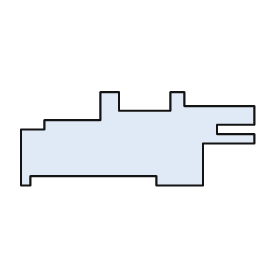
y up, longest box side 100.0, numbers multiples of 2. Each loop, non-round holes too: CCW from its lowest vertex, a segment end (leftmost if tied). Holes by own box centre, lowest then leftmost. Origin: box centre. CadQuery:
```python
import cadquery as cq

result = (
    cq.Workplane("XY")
    .moveTo(-50.0, -20.0)
    .lineTo(-46.0, -20.0)
    .lineTo(-46.0, -16.0)
    .lineTo(8.0, -16.0)
    .lineTo(8.0, -20.0)
    .lineTo(28.0, -20.0)
    .lineTo(28.0, -2.0)
    .lineTo(50.0, -2.0)
    .lineTo(50.0, 2.0)
    .lineTo(34.0, 2.0)
    .lineTo(34.0, 6.0)
    .lineTo(50.0, 6.0)
    .lineTo(50.0, 14.0)
    .lineTo(20.0, 14.0)
    .lineTo(20.0, 20.0)
    .lineTo(14.0, 20.0)
    .lineTo(14.0, 12.0)
    .lineTo(-8.0, 12.0)
    .lineTo(-8.0, 20.0)
    .lineTo(-16.0, 20.0)
    .lineTo(-16.0, 8.0)
    .lineTo(-40.0, 8.0)
    .lineTo(-40.0, 4.0)
    .lineTo(-50.0, 4.0)
    .close()
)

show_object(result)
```